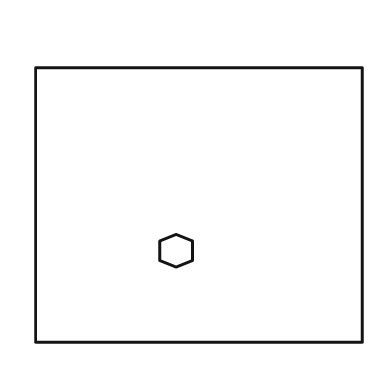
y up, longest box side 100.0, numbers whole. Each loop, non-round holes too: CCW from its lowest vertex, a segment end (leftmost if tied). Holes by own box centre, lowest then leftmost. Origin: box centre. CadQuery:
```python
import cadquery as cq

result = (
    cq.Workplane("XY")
    .moveTo(-50.0, -42.0)
    .lineTo(50.0, -42.0)
    .lineTo(50.0, 42.0)
    .lineTo(-50.0, 42.0)
    .close()
    .moveTo(-7.0, -19.0)
    .lineTo(-2.0, -17.0)
    .lineTo(-2.0, -11.0)
    .lineTo(-7.0, -9.0)
    .lineTo(-12.0, -11.0)
    .lineTo(-12.0, -17.0)
    .close()
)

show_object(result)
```